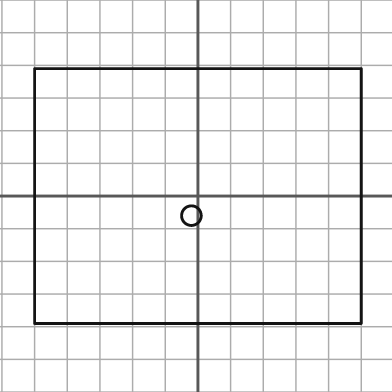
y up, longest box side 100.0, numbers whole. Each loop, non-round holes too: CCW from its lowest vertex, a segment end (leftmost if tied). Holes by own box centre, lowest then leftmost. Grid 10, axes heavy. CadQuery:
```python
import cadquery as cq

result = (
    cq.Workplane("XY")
    .moveTo(-50.0, -39.0)
    .lineTo(50.0, -39.0)
    .lineTo(50.0, 39.0)
    .lineTo(-50.0, 39.0)
    .close()
    .moveTo(-2.0, -6.0)
    .circle(3.0)
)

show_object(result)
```